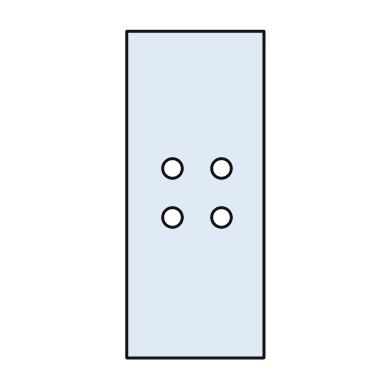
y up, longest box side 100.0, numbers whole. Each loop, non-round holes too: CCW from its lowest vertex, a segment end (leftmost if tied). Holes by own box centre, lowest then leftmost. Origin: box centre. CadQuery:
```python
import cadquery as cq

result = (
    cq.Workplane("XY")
    .moveTo(-21.0, -50.0)
    .lineTo(21.0, -50.0)
    .lineTo(21.0, 50.0)
    .lineTo(-21.0, 50.0)
    .close()
    .moveTo(-7.0, -7.0)
    .circle(3.0)
    .moveTo(8.0, -7.0)
    .circle(3.0)
    .moveTo(-7.0, 8.0)
    .circle(3.0)
    .moveTo(8.0, 8.0)
    .circle(3.0)
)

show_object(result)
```